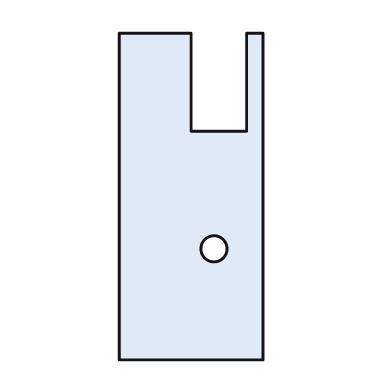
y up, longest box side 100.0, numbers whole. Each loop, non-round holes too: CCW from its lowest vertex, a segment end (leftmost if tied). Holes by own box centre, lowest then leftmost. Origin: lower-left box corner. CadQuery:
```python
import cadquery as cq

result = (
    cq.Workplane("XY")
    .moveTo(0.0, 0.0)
    .lineTo(44.0, 0.0)
    .lineTo(44.0, 100.0)
    .lineTo(39.0, 100.0)
    .lineTo(39.0, 70.0)
    .lineTo(22.0, 70.0)
    .lineTo(22.0, 100.0)
    .lineTo(0.0, 100.0)
    .close()
    .moveTo(29.0, 34.0)
    .circle(4.0)
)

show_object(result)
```